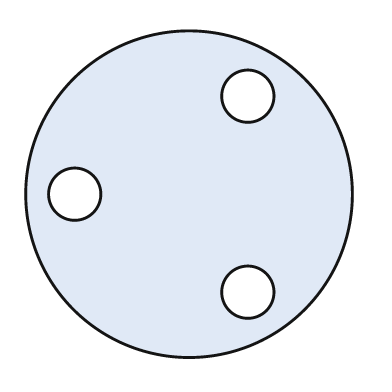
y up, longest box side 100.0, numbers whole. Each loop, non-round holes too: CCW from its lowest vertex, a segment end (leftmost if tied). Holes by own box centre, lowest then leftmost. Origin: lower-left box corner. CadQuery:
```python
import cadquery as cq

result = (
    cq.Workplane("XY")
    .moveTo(50.0, 50.0)
    .circle(50.0)
    .moveTo(68.0, 20.0)
    .circle(8.0)
    .moveTo(15.0, 50.0)
    .circle(8.0)
    .moveTo(68.0, 80.0)
    .circle(8.0)
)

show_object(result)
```